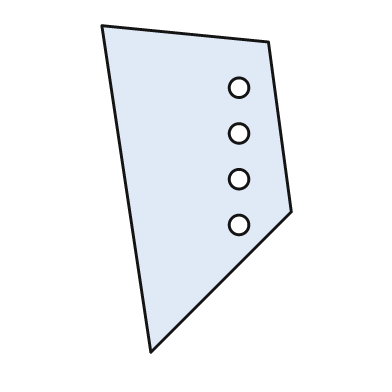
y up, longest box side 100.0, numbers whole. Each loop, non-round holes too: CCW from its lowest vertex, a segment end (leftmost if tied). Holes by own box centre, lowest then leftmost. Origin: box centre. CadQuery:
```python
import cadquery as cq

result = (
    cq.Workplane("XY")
    .moveTo(-14.0, -50.0)
    .lineTo(29.0, -7.0)
    .lineTo(22.0, 45.0)
    .lineTo(-29.0, 50.0)
    .close()
    .moveTo(13.0, -11.0)
    .circle(3.0)
    .moveTo(13.0, 3.0)
    .circle(3.0)
    .moveTo(13.0, 17.0)
    .circle(3.0)
    .moveTo(13.0, 31.0)
    .circle(3.0)
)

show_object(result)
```